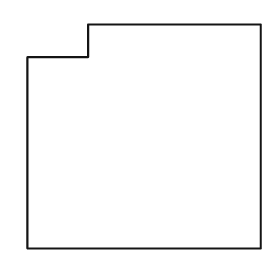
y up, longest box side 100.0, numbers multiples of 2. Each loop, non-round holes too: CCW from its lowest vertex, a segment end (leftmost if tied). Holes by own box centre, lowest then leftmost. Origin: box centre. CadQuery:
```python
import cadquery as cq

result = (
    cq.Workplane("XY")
    .moveTo(-50.0, -48.0)
    .lineTo(50.0, -48.0)
    .lineTo(50.0, 48.0)
    .lineTo(-24.0, 48.0)
    .lineTo(-24.0, 34.0)
    .lineTo(-50.0, 34.0)
    .close()
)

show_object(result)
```